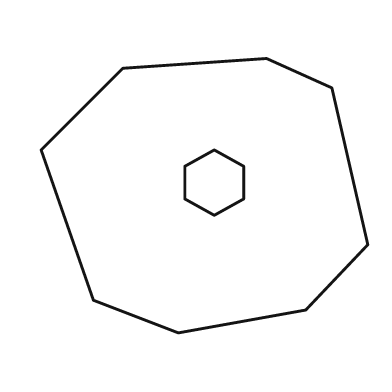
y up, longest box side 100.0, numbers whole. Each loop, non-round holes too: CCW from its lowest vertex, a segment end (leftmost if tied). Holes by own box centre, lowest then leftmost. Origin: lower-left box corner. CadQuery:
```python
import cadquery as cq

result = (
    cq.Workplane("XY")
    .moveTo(42.0, 0.0)
    .lineTo(81.0, 7.0)
    .lineTo(100.0, 27.0)
    .lineTo(89.0, 75.0)
    .lineTo(69.0, 84.0)
    .lineTo(25.0, 81.0)
    .lineTo(0.0, 56.0)
    .lineTo(16.0, 10.0)
    .close()
    .moveTo(53.0, 36.0)
    .lineTo(62.0, 41.0)
    .lineTo(62.0, 51.0)
    .lineTo(53.0, 56.0)
    .lineTo(44.0, 51.0)
    .lineTo(44.0, 41.0)
    .close()
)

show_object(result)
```